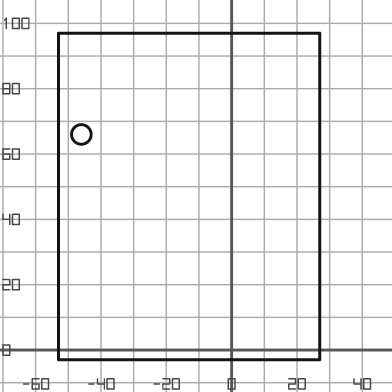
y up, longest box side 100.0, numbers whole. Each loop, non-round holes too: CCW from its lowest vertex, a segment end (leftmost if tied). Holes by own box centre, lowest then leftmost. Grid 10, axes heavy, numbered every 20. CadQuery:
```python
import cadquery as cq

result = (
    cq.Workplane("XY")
    .moveTo(-53.0, -3.0)
    .lineTo(27.0, -3.0)
    .lineTo(27.0, 97.0)
    .lineTo(-53.0, 97.0)
    .close()
    .moveTo(-46.0, 66.0)
    .circle(3.0)
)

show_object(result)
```